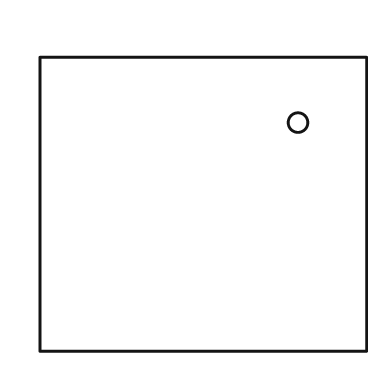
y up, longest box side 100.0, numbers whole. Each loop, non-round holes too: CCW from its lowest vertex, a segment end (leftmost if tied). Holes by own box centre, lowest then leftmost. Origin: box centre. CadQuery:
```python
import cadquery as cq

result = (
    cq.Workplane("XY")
    .moveTo(-50.0, -45.0)
    .lineTo(50.0, -45.0)
    .lineTo(50.0, 45.0)
    .lineTo(-50.0, 45.0)
    .close()
    .moveTo(29.0, 25.0)
    .circle(3.0)
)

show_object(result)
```